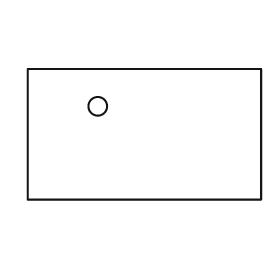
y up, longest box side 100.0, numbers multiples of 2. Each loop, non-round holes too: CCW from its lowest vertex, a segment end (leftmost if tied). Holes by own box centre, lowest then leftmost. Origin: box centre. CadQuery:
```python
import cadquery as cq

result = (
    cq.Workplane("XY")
    .moveTo(-50.0, -28.0)
    .lineTo(50.0, -28.0)
    .lineTo(50.0, 28.0)
    .lineTo(-50.0, 28.0)
    .close()
    .moveTo(-20.0, 12.0)
    .circle(4.0)
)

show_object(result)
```